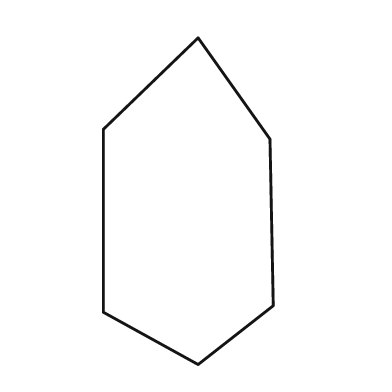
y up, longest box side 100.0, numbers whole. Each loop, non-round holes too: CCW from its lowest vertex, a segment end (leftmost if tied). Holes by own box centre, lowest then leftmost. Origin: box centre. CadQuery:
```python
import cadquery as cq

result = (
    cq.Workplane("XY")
    .moveTo(3.0, -50.0)
    .lineTo(26.0, -32.0)
    .lineTo(25.0, 19.0)
    .lineTo(3.0, 50.0)
    .lineTo(-26.0, 22.0)
    .lineTo(-26.0, -34.0)
    .close()
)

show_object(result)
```